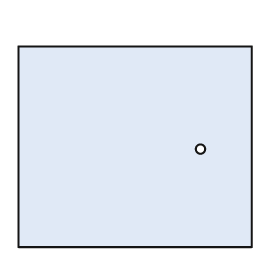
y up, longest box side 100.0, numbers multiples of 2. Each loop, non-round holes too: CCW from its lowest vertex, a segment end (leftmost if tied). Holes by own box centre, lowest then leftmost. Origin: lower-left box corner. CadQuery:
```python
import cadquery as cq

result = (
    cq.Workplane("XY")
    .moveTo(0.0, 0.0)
    .lineTo(100.0, 0.0)
    .lineTo(100.0, 86.0)
    .lineTo(0.0, 86.0)
    .close()
    .moveTo(78.0, 42.0)
    .circle(2.0)
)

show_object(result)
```